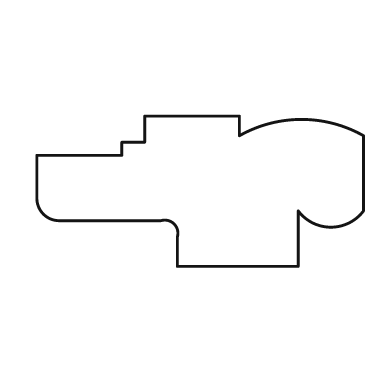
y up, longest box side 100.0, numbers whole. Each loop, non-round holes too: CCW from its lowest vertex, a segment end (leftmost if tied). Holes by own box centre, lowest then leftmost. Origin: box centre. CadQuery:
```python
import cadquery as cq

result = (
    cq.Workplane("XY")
    .moveTo(-7.0, -23.0)
    .lineTo(30.0, -23.0)
    .lineTo(30.0, -6.0)
    .threePointArc((40.0, -11.0), (50.0, -6.0))
    .lineTo(50.0, 17.0)
    .threePointArc((31.0, 22.0), (12.0, 17.0))
    .lineTo(12.0, 23.0)
    .lineTo(-17.0, 23.0)
    .lineTo(-17.0, 15.0)
    .lineTo(-24.0, 15.0)
    .lineTo(-24.0, 11.0)
    .lineTo(-50.0, 11.0)
    .lineTo(-50.0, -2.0)
    .threePointArc((-48.0, -7.0), (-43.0, -9.0))
    .lineTo(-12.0, -9.0)
    .threePointArc((-8.0, -10.0), (-7.0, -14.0))
    .close()
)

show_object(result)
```